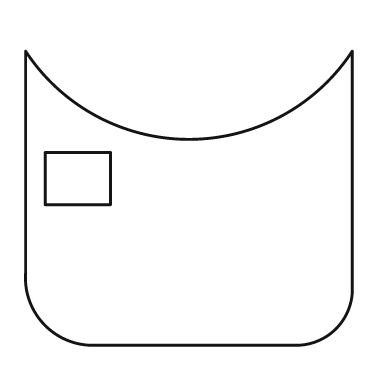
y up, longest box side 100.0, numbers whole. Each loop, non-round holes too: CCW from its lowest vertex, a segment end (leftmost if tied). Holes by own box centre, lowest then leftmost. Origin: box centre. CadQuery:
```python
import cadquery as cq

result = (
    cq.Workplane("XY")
    .moveTo(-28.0, -45.0)
    .lineTo(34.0, -45.0)
    .threePointArc((45.0, -40.0), (50.0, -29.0))
    .lineTo(50.0, 45.0)
    .threePointArc((0.0, 18.0), (-50.0, 45.0))
    .lineTo(-50.0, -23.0)
    .threePointArc((-44.0, -39.0), (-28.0, -45.0))
    .close()
    .moveTo(-44.0, -2.0)
    .lineTo(-24.0, -2.0)
    .lineTo(-24.0, 14.0)
    .lineTo(-44.0, 14.0)
    .close()
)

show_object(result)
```